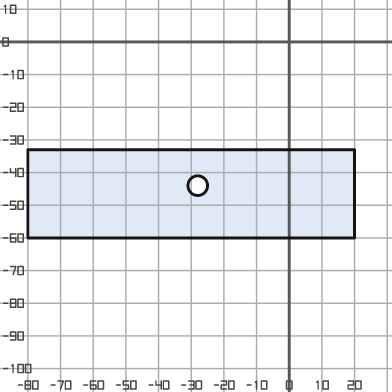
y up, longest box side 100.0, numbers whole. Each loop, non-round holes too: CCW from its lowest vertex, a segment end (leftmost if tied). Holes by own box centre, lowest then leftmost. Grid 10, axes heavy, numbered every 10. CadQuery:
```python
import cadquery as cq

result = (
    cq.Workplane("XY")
    .moveTo(-80.0, -60.0)
    .lineTo(20.0, -60.0)
    .lineTo(20.0, -33.0)
    .lineTo(-80.0, -33.0)
    .close()
    .moveTo(-28.0, -44.0)
    .circle(3.0)
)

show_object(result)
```